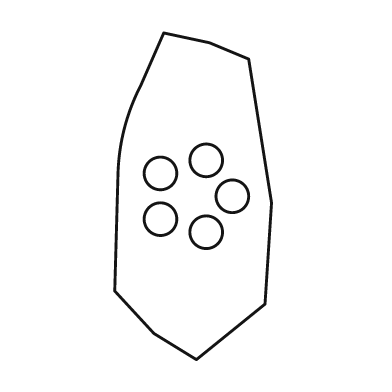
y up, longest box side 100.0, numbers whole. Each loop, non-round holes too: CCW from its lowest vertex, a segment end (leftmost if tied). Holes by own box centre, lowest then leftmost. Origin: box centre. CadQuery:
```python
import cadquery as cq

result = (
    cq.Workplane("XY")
    .moveTo(1.0, -50.0)
    .lineTo(22.0, -33.0)
    .lineTo(24.0, -2.0)
    .lineTo(17.0, 42.0)
    .lineTo(5.0, 47.0)
    .lineTo(-9.0, 50.0)
    .lineTo(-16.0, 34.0)
    .threePointArc((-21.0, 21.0), (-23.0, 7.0))
    .lineTo(-24.0, -29.0)
    .lineTo(-12.0, -42.0)
    .close()
    .moveTo(4.0, -11.0)
    .circle(5.0)
    .moveTo(-10.0, -7.0)
    .circle(5.0)
    .moveTo(12.0, 0.0)
    .circle(5.0)
    .moveTo(-10.0, 7.0)
    .circle(5.0)
    .moveTo(4.0, 11.0)
    .circle(5.0)
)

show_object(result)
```